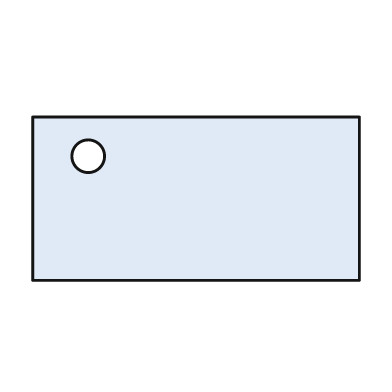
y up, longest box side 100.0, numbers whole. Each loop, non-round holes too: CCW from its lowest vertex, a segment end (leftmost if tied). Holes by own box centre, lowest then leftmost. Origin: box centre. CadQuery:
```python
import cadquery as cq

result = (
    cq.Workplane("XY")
    .moveTo(-50.0, -25.0)
    .lineTo(50.0, -25.0)
    .lineTo(50.0, 25.0)
    .lineTo(-50.0, 25.0)
    .close()
    .moveTo(-33.0, 13.0)
    .circle(5.0)
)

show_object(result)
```